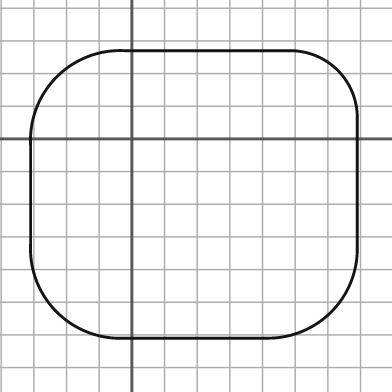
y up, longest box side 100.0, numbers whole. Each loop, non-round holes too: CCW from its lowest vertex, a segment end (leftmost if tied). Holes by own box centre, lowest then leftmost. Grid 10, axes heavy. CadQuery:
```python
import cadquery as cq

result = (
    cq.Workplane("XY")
    .moveTo(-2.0, -61.0)
    .lineTo(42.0, -61.0)
    .threePointArc((61.0, -53.0), (69.0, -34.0))
    .lineTo(69.0, 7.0)
    .threePointArc((63.0, 21.0), (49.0, 27.0))
    .lineTo(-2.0, 27.0)
    .threePointArc((-23.0, 19.0), (-31.0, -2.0))
    .lineTo(-31.0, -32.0)
    .threePointArc((-23.0, -53.0), (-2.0, -61.0))
    .close()
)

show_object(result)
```